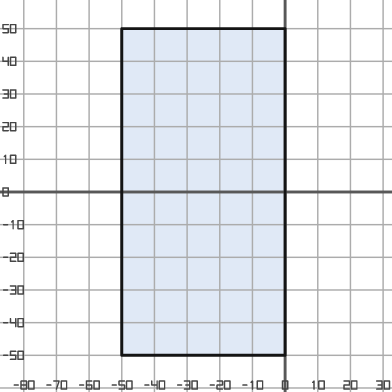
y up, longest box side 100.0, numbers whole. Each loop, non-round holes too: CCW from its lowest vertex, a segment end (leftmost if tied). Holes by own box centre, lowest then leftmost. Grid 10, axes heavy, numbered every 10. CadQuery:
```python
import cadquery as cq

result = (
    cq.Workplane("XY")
    .moveTo(-50.0, -50.0)
    .lineTo(0.0, -50.0)
    .lineTo(0.0, 50.0)
    .lineTo(-50.0, 50.0)
    .close()
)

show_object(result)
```